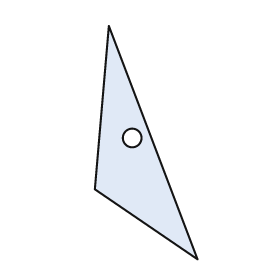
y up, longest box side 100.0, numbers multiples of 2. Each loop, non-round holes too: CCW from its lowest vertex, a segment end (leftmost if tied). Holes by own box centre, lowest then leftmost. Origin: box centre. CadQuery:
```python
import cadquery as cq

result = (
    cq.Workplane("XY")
    .moveTo(22.0, -50.0)
    .lineTo(-16.0, 50.0)
    .lineTo(-22.0, -20.0)
    .close()
    .moveTo(-6.0, 2.0)
    .circle(4.0)
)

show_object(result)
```